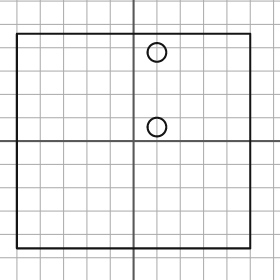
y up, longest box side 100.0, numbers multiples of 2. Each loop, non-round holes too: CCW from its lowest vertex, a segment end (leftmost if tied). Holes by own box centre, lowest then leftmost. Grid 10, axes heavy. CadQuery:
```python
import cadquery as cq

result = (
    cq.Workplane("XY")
    .moveTo(-50.0, -46.0)
    .lineTo(50.0, -46.0)
    .lineTo(50.0, 46.0)
    .lineTo(-50.0, 46.0)
    .close()
    .moveTo(10.0, 6.0)
    .circle(4.0)
    .moveTo(10.0, 38.0)
    .circle(4.0)
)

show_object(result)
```